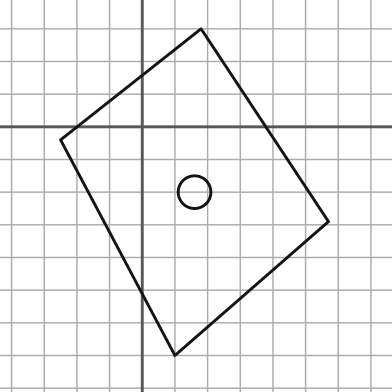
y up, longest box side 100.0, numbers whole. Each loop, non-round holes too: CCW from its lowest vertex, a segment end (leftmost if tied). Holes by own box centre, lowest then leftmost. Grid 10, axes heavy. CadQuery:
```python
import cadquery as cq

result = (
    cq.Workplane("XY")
    .moveTo(10.0, -70.0)
    .lineTo(57.0, -29.0)
    .lineTo(18.0, 30.0)
    .lineTo(-25.0, -4.0)
    .close()
    .moveTo(16.0, -20.0)
    .circle(5.0)
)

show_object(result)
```